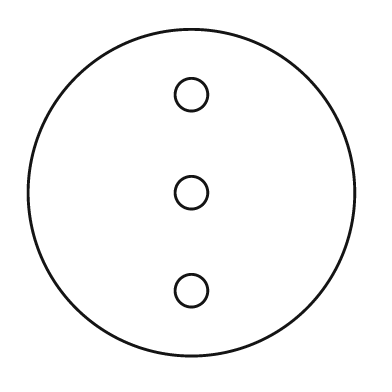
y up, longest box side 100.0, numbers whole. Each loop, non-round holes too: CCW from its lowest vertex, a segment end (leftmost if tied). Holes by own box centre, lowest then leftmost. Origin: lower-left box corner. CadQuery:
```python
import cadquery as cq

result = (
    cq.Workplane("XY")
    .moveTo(50.0, 50.0)
    .circle(50.0)
    .moveTo(50.0, 20.0)
    .circle(5.0)
    .moveTo(50.0, 50.0)
    .circle(5.0)
    .moveTo(50.0, 80.0)
    .circle(5.0)
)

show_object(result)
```